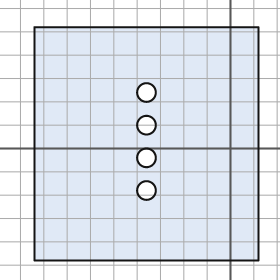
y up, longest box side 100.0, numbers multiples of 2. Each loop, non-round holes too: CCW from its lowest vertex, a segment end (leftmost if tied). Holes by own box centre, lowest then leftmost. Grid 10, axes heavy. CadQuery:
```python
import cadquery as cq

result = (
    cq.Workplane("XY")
    .moveTo(-84.0, -48.0)
    .lineTo(12.0, -48.0)
    .lineTo(12.0, 52.0)
    .lineTo(-84.0, 52.0)
    .close()
    .moveTo(-36.0, -18.0)
    .circle(4.0)
    .moveTo(-36.0, -4.0)
    .circle(4.0)
    .moveTo(-36.0, 10.0)
    .circle(4.0)
    .moveTo(-36.0, 24.0)
    .circle(4.0)
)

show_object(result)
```